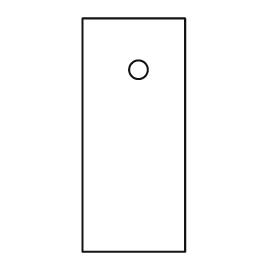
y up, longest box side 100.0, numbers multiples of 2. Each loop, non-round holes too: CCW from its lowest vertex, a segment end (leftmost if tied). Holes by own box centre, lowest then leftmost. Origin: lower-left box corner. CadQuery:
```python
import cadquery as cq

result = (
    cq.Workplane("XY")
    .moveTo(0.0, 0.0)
    .lineTo(44.0, 0.0)
    .lineTo(44.0, 100.0)
    .lineTo(0.0, 100.0)
    .close()
    .moveTo(24.0, 78.0)
    .circle(4.0)
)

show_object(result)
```